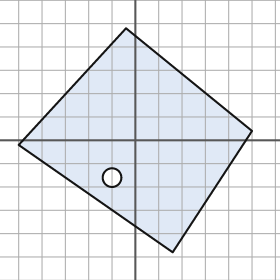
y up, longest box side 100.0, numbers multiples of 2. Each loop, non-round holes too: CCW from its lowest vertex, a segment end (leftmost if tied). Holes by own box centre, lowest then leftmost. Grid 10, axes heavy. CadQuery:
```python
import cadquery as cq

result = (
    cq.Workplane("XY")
    .moveTo(16.0, -48.0)
    .lineTo(50.0, 4.0)
    .lineTo(-4.0, 48.0)
    .lineTo(-50.0, -2.0)
    .close()
    .moveTo(-10.0, -16.0)
    .circle(4.0)
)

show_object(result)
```